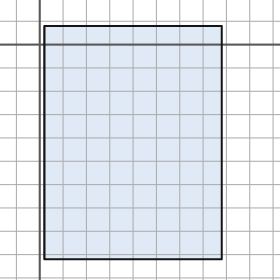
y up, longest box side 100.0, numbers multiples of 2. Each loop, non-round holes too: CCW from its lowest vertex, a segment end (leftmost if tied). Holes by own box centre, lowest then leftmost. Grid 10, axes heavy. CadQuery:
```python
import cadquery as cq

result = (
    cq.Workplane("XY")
    .moveTo(2.0, -92.0)
    .lineTo(78.0, -92.0)
    .lineTo(78.0, 8.0)
    .lineTo(2.0, 8.0)
    .close()
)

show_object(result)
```